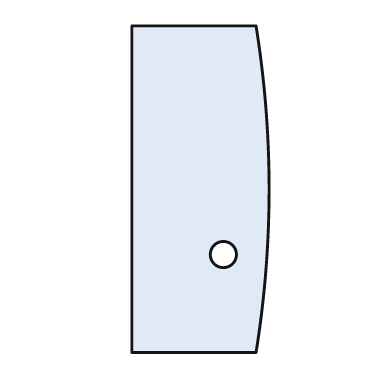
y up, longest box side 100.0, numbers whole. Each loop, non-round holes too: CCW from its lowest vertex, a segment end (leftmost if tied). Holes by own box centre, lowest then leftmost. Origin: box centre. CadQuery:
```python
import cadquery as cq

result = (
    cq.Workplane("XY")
    .moveTo(-21.0, -50.0)
    .lineTo(17.0, -50.0)
    .threePointArc((21.0, 0.0), (17.0, 50.0))
    .lineTo(-21.0, 50.0)
    .close()
    .moveTo(7.0, -20.0)
    .circle(4.0)
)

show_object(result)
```